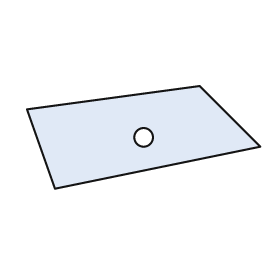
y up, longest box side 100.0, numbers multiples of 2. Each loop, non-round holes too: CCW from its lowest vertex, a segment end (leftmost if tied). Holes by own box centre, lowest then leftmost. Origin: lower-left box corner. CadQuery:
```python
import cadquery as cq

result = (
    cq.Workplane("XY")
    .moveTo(12.0, 0.0)
    .lineTo(100.0, 18.0)
    .lineTo(74.0, 44.0)
    .lineTo(0.0, 34.0)
    .close()
    .moveTo(50.0, 22.0)
    .circle(4.0)
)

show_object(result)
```